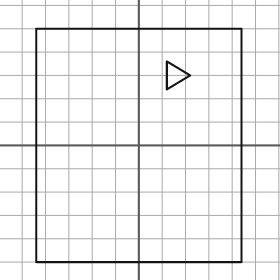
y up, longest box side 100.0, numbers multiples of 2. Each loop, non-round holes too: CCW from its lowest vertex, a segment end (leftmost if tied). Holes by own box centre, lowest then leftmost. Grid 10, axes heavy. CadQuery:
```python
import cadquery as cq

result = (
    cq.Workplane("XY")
    .moveTo(-44.0, -50.0)
    .lineTo(44.0, -50.0)
    .lineTo(44.0, 50.0)
    .lineTo(-44.0, 50.0)
    .close()
    .moveTo(12.0, 24.0)
    .lineTo(22.0, 30.0)
    .lineTo(12.0, 36.0)
    .close()
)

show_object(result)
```